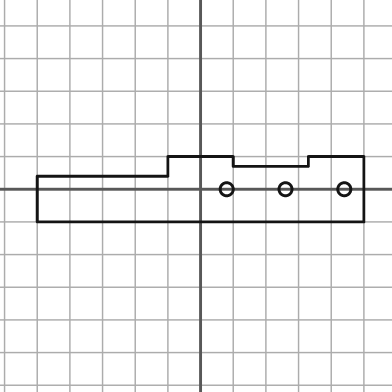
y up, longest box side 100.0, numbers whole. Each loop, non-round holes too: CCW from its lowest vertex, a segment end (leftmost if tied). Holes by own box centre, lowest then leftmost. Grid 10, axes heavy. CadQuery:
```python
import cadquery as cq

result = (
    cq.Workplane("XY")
    .moveTo(-50.0, -10.0)
    .lineTo(50.0, -10.0)
    .lineTo(50.0, 10.0)
    .lineTo(33.0, 10.0)
    .lineTo(33.0, 7.0)
    .lineTo(10.0, 7.0)
    .lineTo(10.0, 10.0)
    .lineTo(-10.0, 10.0)
    .lineTo(-10.0, 4.0)
    .lineTo(-50.0, 4.0)
    .close()
    .moveTo(8.0, 0.0)
    .circle(2.0)
    .moveTo(26.0, 0.0)
    .circle(2.0)
    .moveTo(44.0, 0.0)
    .circle(2.0)
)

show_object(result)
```